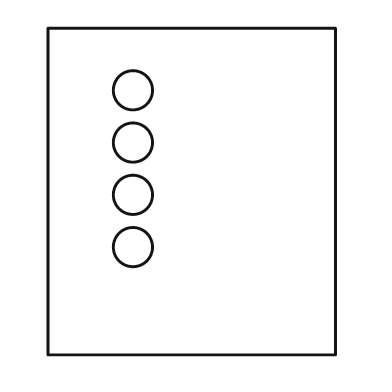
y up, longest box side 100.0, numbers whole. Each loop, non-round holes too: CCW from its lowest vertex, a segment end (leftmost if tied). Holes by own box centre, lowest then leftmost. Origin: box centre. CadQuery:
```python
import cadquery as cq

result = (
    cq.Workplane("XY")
    .moveTo(-44.0, -50.0)
    .lineTo(44.0, -50.0)
    .lineTo(44.0, 50.0)
    .lineTo(-44.0, 50.0)
    .close()
    .moveTo(-18.0, -17.0)
    .circle(6.0)
    .moveTo(-18.0, -1.0)
    .circle(6.0)
    .moveTo(-18.0, 15.0)
    .circle(6.0)
    .moveTo(-18.0, 31.0)
    .circle(6.0)
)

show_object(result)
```